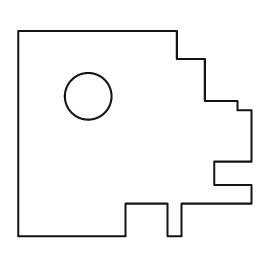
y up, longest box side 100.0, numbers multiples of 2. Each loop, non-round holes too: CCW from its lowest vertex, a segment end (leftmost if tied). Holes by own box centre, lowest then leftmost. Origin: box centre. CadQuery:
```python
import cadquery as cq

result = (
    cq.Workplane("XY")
    .moveTo(-50.0, -44.0)
    .lineTo(-4.0, -44.0)
    .lineTo(-4.0, -30.0)
    .lineTo(14.0, -30.0)
    .lineTo(14.0, -44.0)
    .lineTo(20.0, -44.0)
    .lineTo(20.0, -30.0)
    .lineTo(50.0, -30.0)
    .lineTo(50.0, -22.0)
    .lineTo(34.0, -22.0)
    .lineTo(34.0, -12.0)
    .lineTo(50.0, -12.0)
    .lineTo(50.0, 10.0)
    .lineTo(44.0, 10.0)
    .lineTo(44.0, 14.0)
    .lineTo(30.0, 14.0)
    .lineTo(30.0, 32.0)
    .lineTo(18.0, 32.0)
    .lineTo(18.0, 44.0)
    .lineTo(-50.0, 44.0)
    .close()
    .moveTo(-20.0, 16.0)
    .circle(10.0)
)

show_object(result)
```